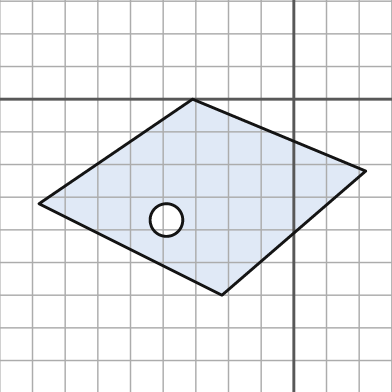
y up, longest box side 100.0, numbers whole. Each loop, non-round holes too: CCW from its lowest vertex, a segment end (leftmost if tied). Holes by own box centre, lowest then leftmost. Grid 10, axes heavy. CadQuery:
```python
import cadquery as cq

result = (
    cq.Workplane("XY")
    .moveTo(-22.0, -60.0)
    .lineTo(22.0, -22.0)
    .lineTo(-31.0, 0.0)
    .lineTo(-78.0, -32.0)
    .close()
    .moveTo(-39.0, -37.0)
    .circle(5.0)
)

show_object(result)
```